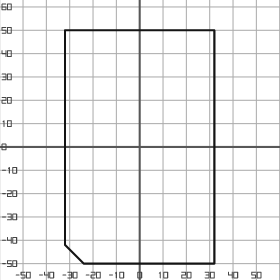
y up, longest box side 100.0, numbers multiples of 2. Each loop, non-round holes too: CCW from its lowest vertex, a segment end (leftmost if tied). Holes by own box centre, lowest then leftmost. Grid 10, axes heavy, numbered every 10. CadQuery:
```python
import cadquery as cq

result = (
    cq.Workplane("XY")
    .moveTo(-24.0, -50.0)
    .lineTo(32.0, -50.0)
    .lineTo(32.0, 50.0)
    .lineTo(-32.0, 50.0)
    .lineTo(-32.0, -42.0)
    .close()
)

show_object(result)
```